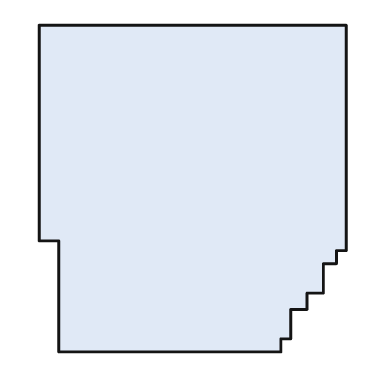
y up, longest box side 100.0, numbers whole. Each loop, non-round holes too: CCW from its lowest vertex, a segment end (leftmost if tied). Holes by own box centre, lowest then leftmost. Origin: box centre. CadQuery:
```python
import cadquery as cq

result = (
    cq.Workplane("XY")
    .moveTo(-41.0, -50.0)
    .lineTo(27.0, -50.0)
    .lineTo(27.0, -46.0)
    .lineTo(30.0, -46.0)
    .lineTo(30.0, -37.0)
    .lineTo(35.0, -37.0)
    .lineTo(35.0, -32.0)
    .lineTo(40.0, -32.0)
    .lineTo(40.0, -23.0)
    .lineTo(44.0, -23.0)
    .lineTo(44.0, -19.0)
    .lineTo(47.0, -19.0)
    .lineTo(47.0, 50.0)
    .lineTo(-47.0, 50.0)
    .lineTo(-47.0, -16.0)
    .lineTo(-41.0, -16.0)
    .close()
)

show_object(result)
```